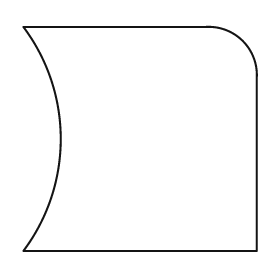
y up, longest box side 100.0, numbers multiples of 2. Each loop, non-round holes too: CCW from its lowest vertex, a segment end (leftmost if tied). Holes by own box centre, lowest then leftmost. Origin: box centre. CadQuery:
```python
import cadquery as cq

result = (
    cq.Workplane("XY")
    .moveTo(-50.0, -48.0)
    .lineTo(50.0, -48.0)
    .lineTo(50.0, 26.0)
    .threePointArc((44.0, 42.0), (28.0, 48.0))
    .lineTo(-50.0, 48.0)
    .threePointArc((-34.0, 0.0), (-50.0, -48.0))
    .close()
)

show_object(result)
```